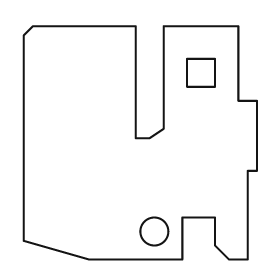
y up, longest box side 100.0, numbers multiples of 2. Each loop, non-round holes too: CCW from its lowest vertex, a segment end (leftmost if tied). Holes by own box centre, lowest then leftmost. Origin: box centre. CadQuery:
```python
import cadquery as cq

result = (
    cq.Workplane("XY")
    .moveTo(-22.0, -50.0)
    .lineTo(18.0, -50.0)
    .lineTo(18.0, -32.0)
    .lineTo(32.0, -32.0)
    .lineTo(32.0, -44.0)
    .lineTo(38.0, -50.0)
    .lineTo(46.0, -50.0)
    .lineTo(46.0, -12.0)
    .lineTo(50.0, -12.0)
    .lineTo(50.0, 18.0)
    .lineTo(42.0, 18.0)
    .lineTo(42.0, 50.0)
    .lineTo(10.0, 50.0)
    .lineTo(10.0, 6.0)
    .lineTo(4.0, 2.0)
    .lineTo(-2.0, 2.0)
    .lineTo(-2.0, 50.0)
    .lineTo(-46.0, 50.0)
    .lineTo(-50.0, 46.0)
    .lineTo(-50.0, -42.0)
    .close()
    .moveTo(6.0, -38.0)
    .circle(6.0)
    .moveTo(20.0, 24.0)
    .lineTo(32.0, 24.0)
    .lineTo(32.0, 36.0)
    .lineTo(20.0, 36.0)
    .close()
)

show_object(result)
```